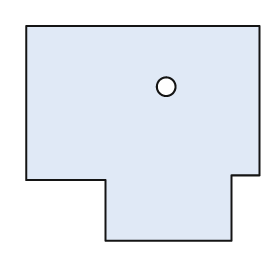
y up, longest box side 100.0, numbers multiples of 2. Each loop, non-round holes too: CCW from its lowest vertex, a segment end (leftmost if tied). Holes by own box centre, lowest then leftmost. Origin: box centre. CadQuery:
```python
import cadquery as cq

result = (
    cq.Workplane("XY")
    .moveTo(-16.0, -46.0)
    .lineTo(38.0, -46.0)
    .lineTo(38.0, -18.0)
    .lineTo(50.0, -18.0)
    .lineTo(50.0, 46.0)
    .lineTo(-50.0, 46.0)
    .lineTo(-50.0, -20.0)
    .lineTo(-16.0, -20.0)
    .close()
    .moveTo(10.0, 20.0)
    .circle(4.0)
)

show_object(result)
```